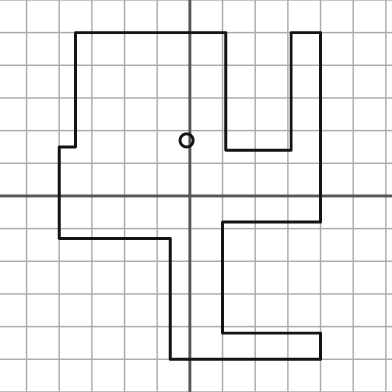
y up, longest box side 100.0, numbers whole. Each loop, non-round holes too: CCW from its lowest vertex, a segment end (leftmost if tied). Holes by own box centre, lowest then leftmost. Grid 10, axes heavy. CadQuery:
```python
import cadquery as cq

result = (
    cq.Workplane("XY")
    .moveTo(-6.0, -50.0)
    .lineTo(40.0, -50.0)
    .lineTo(40.0, -42.0)
    .lineTo(10.0, -42.0)
    .lineTo(10.0, -8.0)
    .lineTo(40.0, -8.0)
    .lineTo(40.0, 50.0)
    .lineTo(31.0, 50.0)
    .lineTo(31.0, 14.0)
    .lineTo(11.0, 14.0)
    .lineTo(11.0, 50.0)
    .lineTo(-35.0, 50.0)
    .lineTo(-35.0, 15.0)
    .lineTo(-40.0, 15.0)
    .lineTo(-40.0, -13.0)
    .lineTo(-6.0, -13.0)
    .close()
    .moveTo(-1.0, 17.0)
    .circle(2.0)
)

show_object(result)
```